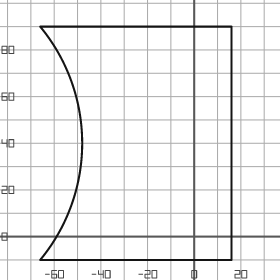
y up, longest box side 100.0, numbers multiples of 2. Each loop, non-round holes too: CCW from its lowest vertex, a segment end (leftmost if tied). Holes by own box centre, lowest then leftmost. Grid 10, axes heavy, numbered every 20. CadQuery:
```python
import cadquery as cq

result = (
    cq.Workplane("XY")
    .moveTo(-66.0, -10.0)
    .lineTo(16.0, -10.0)
    .lineTo(16.0, 90.0)
    .lineTo(-66.0, 90.0)
    .threePointArc((-48.0, 40.0), (-66.0, -10.0))
    .close()
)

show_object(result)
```